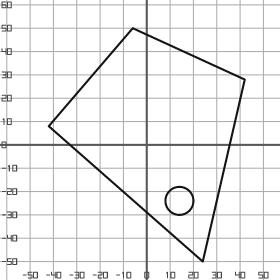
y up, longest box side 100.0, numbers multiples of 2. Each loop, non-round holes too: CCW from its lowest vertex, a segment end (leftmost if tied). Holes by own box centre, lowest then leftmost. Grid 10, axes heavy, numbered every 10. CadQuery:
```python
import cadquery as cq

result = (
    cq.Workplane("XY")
    .moveTo(24.0, -50.0)
    .lineTo(42.0, 28.0)
    .lineTo(-6.0, 50.0)
    .lineTo(-42.0, 8.0)
    .close()
    .moveTo(14.0, -24.0)
    .circle(6.0)
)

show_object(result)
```